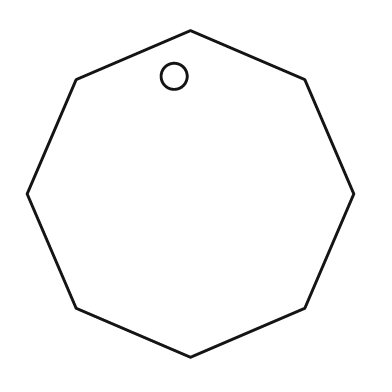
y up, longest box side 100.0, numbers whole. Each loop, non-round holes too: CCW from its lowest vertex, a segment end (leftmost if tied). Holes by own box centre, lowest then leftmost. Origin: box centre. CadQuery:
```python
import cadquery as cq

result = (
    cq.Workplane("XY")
    .moveTo(0.0, -50.0)
    .lineTo(35.0, -35.0)
    .lineTo(50.0, 0.0)
    .lineTo(35.0, 35.0)
    .lineTo(0.0, 50.0)
    .lineTo(-35.0, 35.0)
    .lineTo(-50.0, 0.0)
    .lineTo(-35.0, -35.0)
    .close()
    .moveTo(-5.0, 36.0)
    .circle(4.0)
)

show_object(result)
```